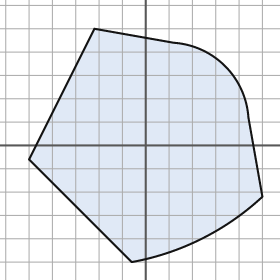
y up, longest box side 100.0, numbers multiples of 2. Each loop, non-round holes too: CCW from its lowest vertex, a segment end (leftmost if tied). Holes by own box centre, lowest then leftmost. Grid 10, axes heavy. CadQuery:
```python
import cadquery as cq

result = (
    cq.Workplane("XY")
    .moveTo(-6.0, -50.0)
    .threePointArc((24.0, -40.0), (50.0, -22.0))
    .lineTo(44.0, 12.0)
    .threePointArc((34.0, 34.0), (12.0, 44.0))
    .lineTo(-22.0, 50.0)
    .lineTo(-50.0, -6.0)
    .close()
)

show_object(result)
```